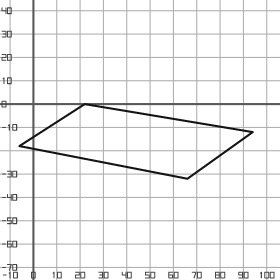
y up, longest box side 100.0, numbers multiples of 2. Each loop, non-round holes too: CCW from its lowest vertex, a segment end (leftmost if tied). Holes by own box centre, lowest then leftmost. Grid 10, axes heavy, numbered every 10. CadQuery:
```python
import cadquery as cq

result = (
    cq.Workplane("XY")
    .moveTo(66.0, -32.0)
    .lineTo(94.0, -12.0)
    .lineTo(22.0, 0.0)
    .lineTo(-6.0, -18.0)
    .close()
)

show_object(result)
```